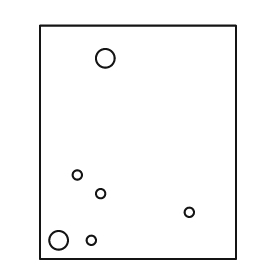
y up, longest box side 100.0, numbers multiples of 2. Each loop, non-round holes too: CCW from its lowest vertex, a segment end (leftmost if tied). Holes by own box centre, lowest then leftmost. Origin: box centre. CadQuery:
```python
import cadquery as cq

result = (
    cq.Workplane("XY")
    .moveTo(-42.0, -50.0)
    .lineTo(42.0, -50.0)
    .lineTo(42.0, 50.0)
    .lineTo(-42.0, 50.0)
    .close()
    .moveTo(-34.0, -42.0)
    .circle(4.0)
    .moveTo(-20.0, -42.0)
    .circle(2.0)
    .moveTo(22.0, -30.0)
    .circle(2.0)
    .moveTo(-16.0, -22.0)
    .circle(2.0)
    .moveTo(-26.0, -14.0)
    .circle(2.0)
    .moveTo(-14.0, 36.0)
    .circle(4.0)
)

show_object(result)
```